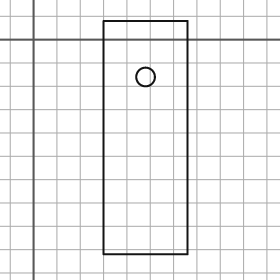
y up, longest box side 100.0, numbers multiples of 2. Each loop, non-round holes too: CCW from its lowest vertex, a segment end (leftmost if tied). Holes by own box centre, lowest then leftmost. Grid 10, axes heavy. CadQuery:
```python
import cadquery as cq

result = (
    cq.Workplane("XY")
    .moveTo(30.0, -92.0)
    .lineTo(66.0, -92.0)
    .lineTo(66.0, 8.0)
    .lineTo(30.0, 8.0)
    .close()
    .moveTo(48.0, -16.0)
    .circle(4.0)
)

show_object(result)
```